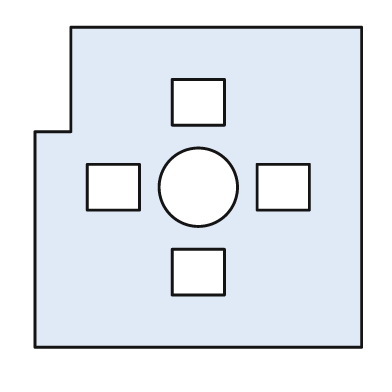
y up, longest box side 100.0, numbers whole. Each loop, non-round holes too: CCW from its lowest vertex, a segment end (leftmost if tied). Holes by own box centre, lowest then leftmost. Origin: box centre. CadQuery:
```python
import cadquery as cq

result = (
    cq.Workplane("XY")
    .moveTo(-50.0, -49.0)
    .lineTo(50.0, -49.0)
    .lineTo(50.0, 49.0)
    .lineTo(-39.0, 49.0)
    .lineTo(-39.0, 17.0)
    .lineTo(-50.0, 17.0)
    .close()
    .moveTo(-8.0, -33.0)
    .lineTo(8.0, -33.0)
    .lineTo(8.0, -19.0)
    .lineTo(-8.0, -19.0)
    .close()
    .moveTo(-34.0, -7.0)
    .lineTo(-18.0, -7.0)
    .lineTo(-18.0, 7.0)
    .lineTo(-34.0, 7.0)
    .close()
    .moveTo(0.0, 0.0)
    .circle(12.0)
    .moveTo(18.0, -7.0)
    .lineTo(34.0, -7.0)
    .lineTo(34.0, 7.0)
    .lineTo(18.0, 7.0)
    .close()
    .moveTo(-8.0, 19.0)
    .lineTo(8.0, 19.0)
    .lineTo(8.0, 33.0)
    .lineTo(-8.0, 33.0)
    .close()
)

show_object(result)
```